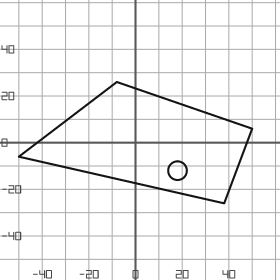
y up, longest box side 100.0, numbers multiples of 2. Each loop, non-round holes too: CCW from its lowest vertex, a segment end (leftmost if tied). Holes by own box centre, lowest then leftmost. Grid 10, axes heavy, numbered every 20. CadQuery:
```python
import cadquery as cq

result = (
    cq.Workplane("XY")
    .moveTo(38.0, -26.0)
    .lineTo(50.0, 6.0)
    .lineTo(-8.0, 26.0)
    .lineTo(-50.0, -6.0)
    .close()
    .moveTo(18.0, -12.0)
    .circle(4.0)
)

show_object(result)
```